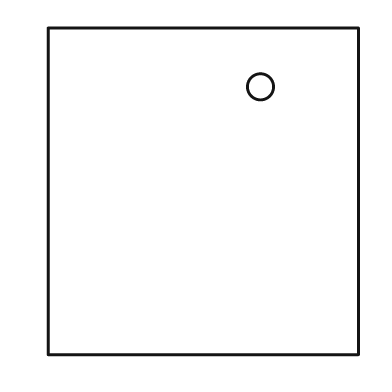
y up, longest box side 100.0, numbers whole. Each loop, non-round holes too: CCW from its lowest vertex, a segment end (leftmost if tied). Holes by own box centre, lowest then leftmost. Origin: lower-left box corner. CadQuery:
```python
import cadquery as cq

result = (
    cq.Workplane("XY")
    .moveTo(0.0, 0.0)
    .lineTo(95.0, 0.0)
    .lineTo(95.0, 100.0)
    .lineTo(0.0, 100.0)
    .close()
    .moveTo(65.0, 82.0)
    .circle(4.0)
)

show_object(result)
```